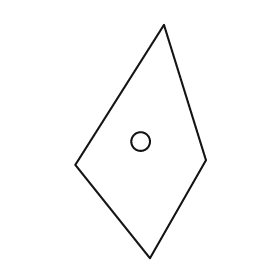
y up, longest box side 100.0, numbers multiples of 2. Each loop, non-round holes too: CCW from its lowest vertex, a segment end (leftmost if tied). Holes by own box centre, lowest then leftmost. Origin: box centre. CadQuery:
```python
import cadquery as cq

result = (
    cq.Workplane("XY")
    .moveTo(4.0, -50.0)
    .lineTo(28.0, -8.0)
    .lineTo(10.0, 50.0)
    .lineTo(-28.0, -10.0)
    .close()
    .moveTo(0.0, 0.0)
    .circle(4.0)
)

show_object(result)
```